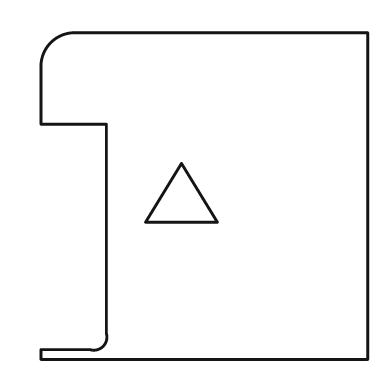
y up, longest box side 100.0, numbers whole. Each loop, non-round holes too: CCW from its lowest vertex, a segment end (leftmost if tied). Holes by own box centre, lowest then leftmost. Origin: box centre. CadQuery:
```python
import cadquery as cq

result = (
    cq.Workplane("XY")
    .moveTo(-50.0, -50.0)
    .lineTo(50.0, -50.0)
    .lineTo(50.0, 50.0)
    .lineTo(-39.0, 50.0)
    .threePointArc((-47.0, 47.0), (-50.0, 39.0))
    .lineTo(-50.0, 22.0)
    .lineTo(-30.0, 22.0)
    .lineTo(-30.0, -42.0)
    .threePointArc((-31.0, -46.0), (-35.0, -47.0))
    .lineTo(-50.0, -47.0)
    .close()
    .moveTo(-18.0, -8.0)
    .lineTo(4.0, -8.0)
    .lineTo(-7.0, 10.0)
    .close()
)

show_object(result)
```